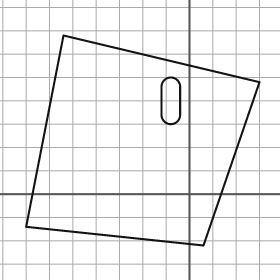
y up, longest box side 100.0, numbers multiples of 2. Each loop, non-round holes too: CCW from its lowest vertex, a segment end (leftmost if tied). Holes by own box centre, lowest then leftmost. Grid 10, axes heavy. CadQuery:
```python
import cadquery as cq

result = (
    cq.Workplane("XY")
    .moveTo(6.0, -22.0)
    .lineTo(30.0, 48.0)
    .lineTo(-54.0, 68.0)
    .lineTo(-70.0, -14.0)
    .close()
    .moveTo(-12.0, 34.0)
    .threePointArc((-8.0, 30.0), (-4.0, 34.0))
    .lineTo(-4.0, 46.0)
    .threePointArc((-8.0, 50.0), (-12.0, 46.0))
    .close()
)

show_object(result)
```